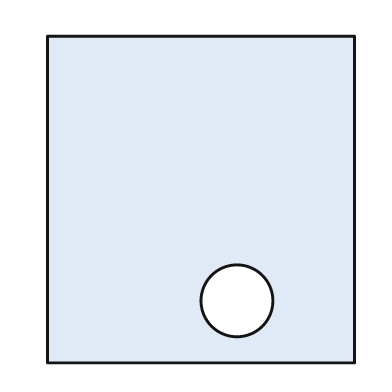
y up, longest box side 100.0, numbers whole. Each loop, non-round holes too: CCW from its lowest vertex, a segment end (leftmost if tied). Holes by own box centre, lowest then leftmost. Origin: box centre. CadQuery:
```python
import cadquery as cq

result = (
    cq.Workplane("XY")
    .moveTo(-47.0, -50.0)
    .lineTo(47.0, -50.0)
    .lineTo(47.0, 50.0)
    .lineTo(-47.0, 50.0)
    .close()
    .moveTo(11.0, -31.0)
    .circle(11.0)
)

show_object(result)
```